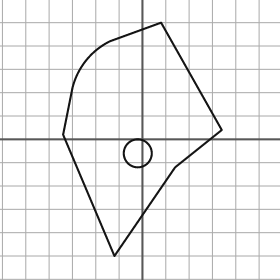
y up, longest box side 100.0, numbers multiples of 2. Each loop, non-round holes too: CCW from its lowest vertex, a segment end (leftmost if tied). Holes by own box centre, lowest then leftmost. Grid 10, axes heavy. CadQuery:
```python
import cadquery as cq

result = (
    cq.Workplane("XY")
    .moveTo(-12.0, -50.0)
    .lineTo(14.0, -12.0)
    .lineTo(34.0, 4.0)
    .lineTo(8.0, 50.0)
    .lineTo(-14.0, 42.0)
    .threePointArc((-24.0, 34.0), (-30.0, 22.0))
    .lineTo(-34.0, 2.0)
    .close()
    .moveTo(-2.0, -6.0)
    .circle(6.0)
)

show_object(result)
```